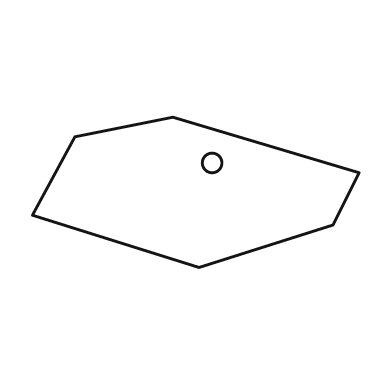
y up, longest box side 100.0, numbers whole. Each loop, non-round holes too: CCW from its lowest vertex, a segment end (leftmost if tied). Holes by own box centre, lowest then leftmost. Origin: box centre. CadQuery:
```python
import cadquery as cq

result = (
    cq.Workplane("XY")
    .moveTo(1.0, -23.0)
    .lineTo(42.0, -10.0)
    .lineTo(50.0, 6.0)
    .lineTo(-7.0, 23.0)
    .lineTo(-37.0, 17.0)
    .lineTo(-50.0, -7.0)
    .close()
    .moveTo(5.0, 9.0)
    .circle(3.0)
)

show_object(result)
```